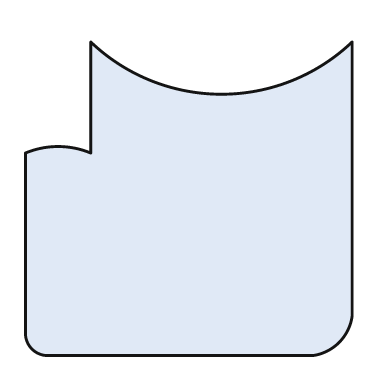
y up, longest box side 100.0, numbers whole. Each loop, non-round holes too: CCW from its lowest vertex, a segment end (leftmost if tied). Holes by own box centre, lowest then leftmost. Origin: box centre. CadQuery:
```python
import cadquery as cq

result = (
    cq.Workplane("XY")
    .moveTo(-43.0, -48.0)
    .lineTo(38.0, -48.0)
    .threePointArc((46.0, -44.0), (50.0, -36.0))
    .lineTo(50.0, 48.0)
    .threePointArc((10.0, 32.0), (-30.0, 48.0))
    .lineTo(-30.0, 14.0)
    .threePointArc((-40.0, 16.0), (-50.0, 14.0))
    .lineTo(-50.0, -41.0)
    .threePointArc((-48.0, -46.0), (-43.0, -48.0))
    .close()
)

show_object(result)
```